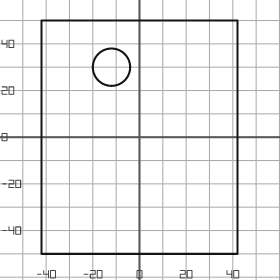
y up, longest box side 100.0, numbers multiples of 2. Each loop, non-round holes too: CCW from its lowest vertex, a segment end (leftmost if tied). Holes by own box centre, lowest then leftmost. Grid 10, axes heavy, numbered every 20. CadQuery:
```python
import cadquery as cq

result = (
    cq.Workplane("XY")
    .moveTo(-42.0, -50.0)
    .lineTo(42.0, -50.0)
    .lineTo(42.0, 50.0)
    .lineTo(-42.0, 50.0)
    .close()
    .moveTo(-12.0, 30.0)
    .circle(8.0)
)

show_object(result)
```